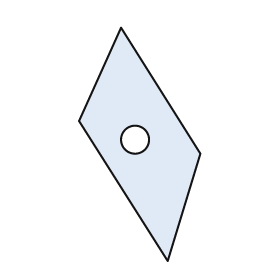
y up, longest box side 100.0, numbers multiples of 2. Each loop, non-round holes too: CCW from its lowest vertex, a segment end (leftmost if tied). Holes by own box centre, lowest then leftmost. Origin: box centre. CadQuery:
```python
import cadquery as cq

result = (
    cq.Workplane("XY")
    .moveTo(12.0, -50.0)
    .lineTo(26.0, -4.0)
    .lineTo(-8.0, 50.0)
    .lineTo(-26.0, 10.0)
    .close()
    .moveTo(-2.0, 2.0)
    .circle(6.0)
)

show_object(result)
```